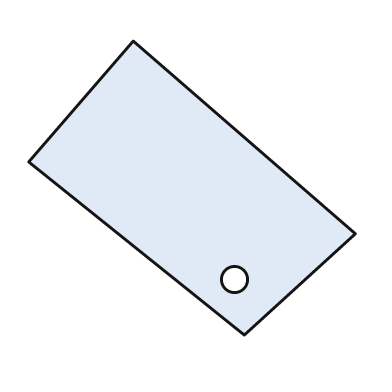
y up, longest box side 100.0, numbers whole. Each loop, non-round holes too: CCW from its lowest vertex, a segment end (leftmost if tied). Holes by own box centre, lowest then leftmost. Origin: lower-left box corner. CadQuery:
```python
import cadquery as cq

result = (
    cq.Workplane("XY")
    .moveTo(66.0, 0.0)
    .lineTo(100.0, 31.0)
    .lineTo(32.0, 90.0)
    .lineTo(0.0, 53.0)
    .close()
    .moveTo(63.0, 17.0)
    .circle(4.0)
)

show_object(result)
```